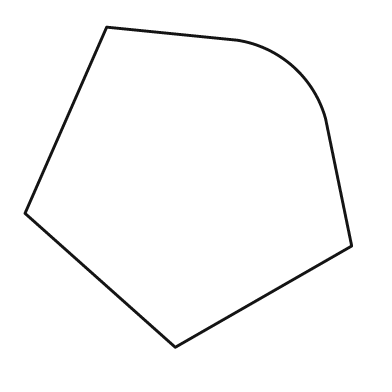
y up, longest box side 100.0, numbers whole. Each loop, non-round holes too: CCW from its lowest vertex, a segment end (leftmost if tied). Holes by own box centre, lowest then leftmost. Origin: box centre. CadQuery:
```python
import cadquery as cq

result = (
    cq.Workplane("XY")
    .moveTo(-4.0, -49.0)
    .lineTo(50.0, -18.0)
    .lineTo(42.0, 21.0)
    .threePointArc((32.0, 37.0), (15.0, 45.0))
    .lineTo(-25.0, 49.0)
    .lineTo(-50.0, -8.0)
    .close()
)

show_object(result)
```